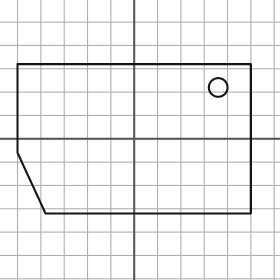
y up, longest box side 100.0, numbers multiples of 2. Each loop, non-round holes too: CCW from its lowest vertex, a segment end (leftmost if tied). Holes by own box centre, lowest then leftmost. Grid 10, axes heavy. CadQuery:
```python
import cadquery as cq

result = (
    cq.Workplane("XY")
    .moveTo(-38.0, -32.0)
    .lineTo(50.0, -32.0)
    .lineTo(50.0, 32.0)
    .lineTo(-50.0, 32.0)
    .lineTo(-50.0, -6.0)
    .close()
    .moveTo(36.0, 22.0)
    .circle(4.0)
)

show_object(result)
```